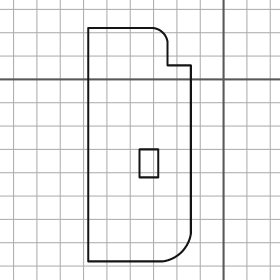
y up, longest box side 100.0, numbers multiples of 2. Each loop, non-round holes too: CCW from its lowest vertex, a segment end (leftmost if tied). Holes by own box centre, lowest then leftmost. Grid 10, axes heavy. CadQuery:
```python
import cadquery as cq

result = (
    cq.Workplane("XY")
    .moveTo(-58.0, -78.0)
    .lineTo(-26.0, -78.0)
    .threePointArc((-18.0, -74.0), (-14.0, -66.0))
    .lineTo(-14.0, 6.0)
    .lineTo(-24.0, 6.0)
    .lineTo(-24.0, 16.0)
    .threePointArc((-26.0, 20.0), (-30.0, 22.0))
    .lineTo(-58.0, 22.0)
    .close()
    .moveTo(-36.0, -42.0)
    .lineTo(-28.0, -42.0)
    .lineTo(-28.0, -30.0)
    .lineTo(-36.0, -30.0)
    .close()
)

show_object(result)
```